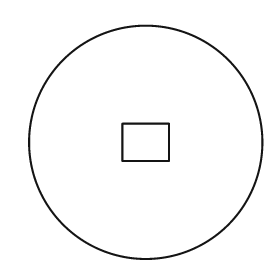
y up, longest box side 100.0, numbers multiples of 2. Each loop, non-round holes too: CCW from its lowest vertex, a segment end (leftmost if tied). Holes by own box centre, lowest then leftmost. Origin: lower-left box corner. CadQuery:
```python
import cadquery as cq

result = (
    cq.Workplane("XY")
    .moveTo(50.0, 50.0)
    .circle(50.0)
    .moveTo(40.0, 42.0)
    .lineTo(60.0, 42.0)
    .lineTo(60.0, 58.0)
    .lineTo(40.0, 58.0)
    .close()
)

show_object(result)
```